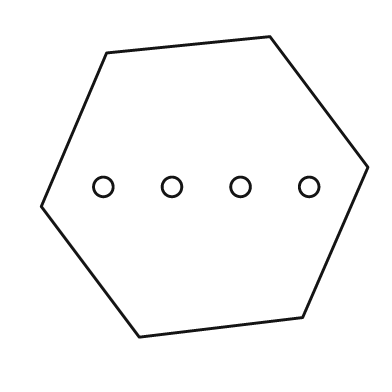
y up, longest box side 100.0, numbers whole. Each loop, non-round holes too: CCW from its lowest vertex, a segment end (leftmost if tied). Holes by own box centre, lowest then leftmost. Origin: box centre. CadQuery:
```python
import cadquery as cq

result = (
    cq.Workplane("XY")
    .moveTo(-20.0, -46.0)
    .lineTo(30.0, -40.0)
    .lineTo(50.0, 6.0)
    .lineTo(20.0, 46.0)
    .lineTo(-30.0, 41.0)
    .lineTo(-50.0, -6.0)
    .close()
    .moveTo(-31.0, 0.0)
    .circle(3.0)
    .moveTo(-10.0, 0.0)
    .circle(3.0)
    .moveTo(11.0, 0.0)
    .circle(3.0)
    .moveTo(32.0, 0.0)
    .circle(3.0)
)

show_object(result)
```